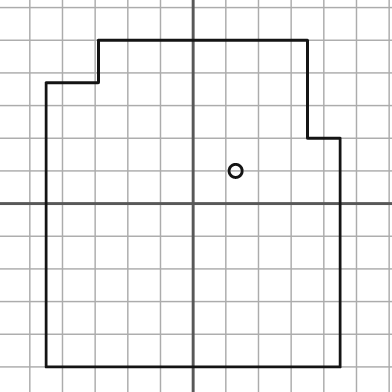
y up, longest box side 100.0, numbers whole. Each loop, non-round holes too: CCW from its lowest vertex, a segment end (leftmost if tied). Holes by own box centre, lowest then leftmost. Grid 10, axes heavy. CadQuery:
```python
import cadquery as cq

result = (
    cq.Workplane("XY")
    .moveTo(-45.0, -50.0)
    .lineTo(45.0, -50.0)
    .lineTo(45.0, 20.0)
    .lineTo(35.0, 20.0)
    .lineTo(35.0, 50.0)
    .lineTo(-29.0, 50.0)
    .lineTo(-29.0, 37.0)
    .lineTo(-45.0, 37.0)
    .close()
    .moveTo(13.0, 10.0)
    .circle(2.0)
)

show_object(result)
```